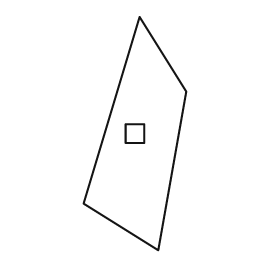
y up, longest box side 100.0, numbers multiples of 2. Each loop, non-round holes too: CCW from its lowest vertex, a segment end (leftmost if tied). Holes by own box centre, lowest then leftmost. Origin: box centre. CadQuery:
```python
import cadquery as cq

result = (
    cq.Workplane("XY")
    .moveTo(10.0, -50.0)
    .lineTo(22.0, 18.0)
    .lineTo(2.0, 50.0)
    .lineTo(-22.0, -30.0)
    .close()
    .moveTo(-4.0, -4.0)
    .lineTo(4.0, -4.0)
    .lineTo(4.0, 4.0)
    .lineTo(-4.0, 4.0)
    .close()
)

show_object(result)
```